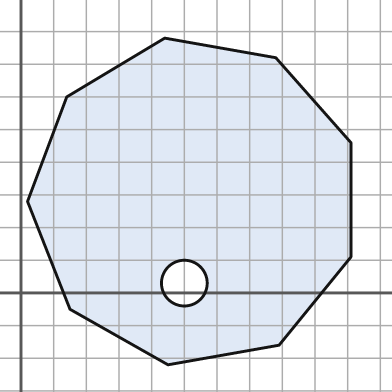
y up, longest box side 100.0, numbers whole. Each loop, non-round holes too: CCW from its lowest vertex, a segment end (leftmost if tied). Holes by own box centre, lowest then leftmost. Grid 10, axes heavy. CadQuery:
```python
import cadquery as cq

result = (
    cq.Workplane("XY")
    .moveTo(45.0, -22.0)
    .lineTo(79.0, -16.0)
    .lineTo(101.0, 11.0)
    .lineTo(101.0, 46.0)
    .lineTo(78.0, 72.0)
    .lineTo(44.0, 78.0)
    .lineTo(14.0, 60.0)
    .lineTo(2.0, 28.0)
    .lineTo(15.0, -5.0)
    .close()
    .moveTo(50.0, 3.0)
    .circle(7.0)
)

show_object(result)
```